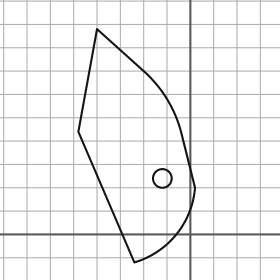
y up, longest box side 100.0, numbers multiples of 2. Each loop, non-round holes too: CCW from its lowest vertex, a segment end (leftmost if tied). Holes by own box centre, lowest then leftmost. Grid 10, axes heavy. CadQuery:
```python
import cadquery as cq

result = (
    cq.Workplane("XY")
    .moveTo(-24.0, -12.0)
    .threePointArc((-6.0, 0.0), (2.0, 20.0))
    .lineTo(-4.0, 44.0)
    .threePointArc((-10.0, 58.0), (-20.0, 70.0))
    .lineTo(-40.0, 88.0)
    .lineTo(-48.0, 44.0)
    .close()
    .moveTo(-12.0, 24.0)
    .circle(4.0)
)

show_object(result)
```